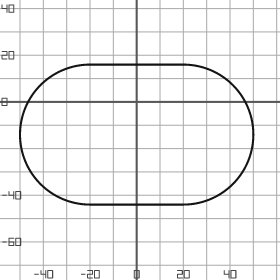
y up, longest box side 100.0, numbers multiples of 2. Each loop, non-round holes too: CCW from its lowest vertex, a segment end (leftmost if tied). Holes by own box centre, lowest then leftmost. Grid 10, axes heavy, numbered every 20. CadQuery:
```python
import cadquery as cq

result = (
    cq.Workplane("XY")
    .moveTo(-20.0, -44.0)
    .lineTo(20.0, -44.0)
    .threePointArc((50.0, -14.0), (20.0, 16.0))
    .lineTo(-20.0, 16.0)
    .threePointArc((-50.0, -14.0), (-20.0, -44.0))
    .close()
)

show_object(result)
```